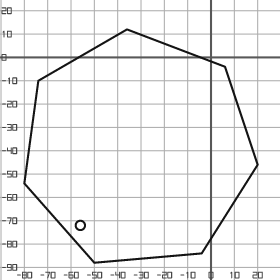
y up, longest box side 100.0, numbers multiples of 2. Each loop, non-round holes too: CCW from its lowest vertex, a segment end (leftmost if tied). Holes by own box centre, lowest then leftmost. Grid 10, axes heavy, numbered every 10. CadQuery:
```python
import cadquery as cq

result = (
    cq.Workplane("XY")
    .moveTo(-50.0, -88.0)
    .lineTo(-4.0, -84.0)
    .lineTo(20.0, -46.0)
    .lineTo(6.0, -4.0)
    .lineTo(-36.0, 12.0)
    .lineTo(-74.0, -10.0)
    .lineTo(-80.0, -54.0)
    .close()
    .moveTo(-56.0, -72.0)
    .circle(2.0)
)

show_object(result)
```